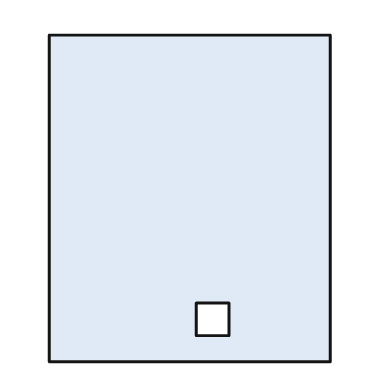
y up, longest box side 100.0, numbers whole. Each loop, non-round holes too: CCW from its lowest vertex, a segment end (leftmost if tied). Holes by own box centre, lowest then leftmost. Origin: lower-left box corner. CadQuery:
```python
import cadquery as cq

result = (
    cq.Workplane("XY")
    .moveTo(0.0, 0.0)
    .lineTo(86.0, 0.0)
    .lineTo(86.0, 100.0)
    .lineTo(0.0, 100.0)
    .close()
    .moveTo(45.0, 8.0)
    .lineTo(55.0, 8.0)
    .lineTo(55.0, 18.0)
    .lineTo(45.0, 18.0)
    .close()
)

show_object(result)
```